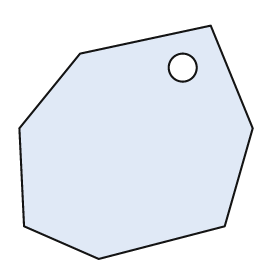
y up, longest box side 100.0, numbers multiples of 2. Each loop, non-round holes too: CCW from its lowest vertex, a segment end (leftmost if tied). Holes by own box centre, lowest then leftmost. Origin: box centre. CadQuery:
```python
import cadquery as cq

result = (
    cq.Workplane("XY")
    .moveTo(-16.0, -50.0)
    .lineTo(38.0, -36.0)
    .lineTo(50.0, 6.0)
    .lineTo(32.0, 50.0)
    .lineTo(-24.0, 38.0)
    .lineTo(-50.0, 6.0)
    .lineTo(-48.0, -36.0)
    .close()
    .moveTo(20.0, 32.0)
    .circle(6.0)
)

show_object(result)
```